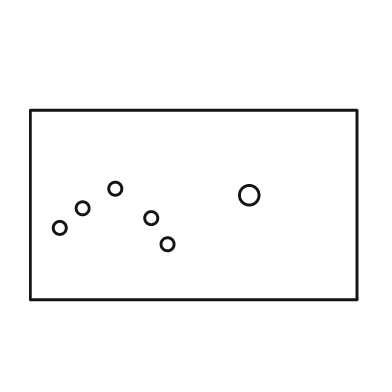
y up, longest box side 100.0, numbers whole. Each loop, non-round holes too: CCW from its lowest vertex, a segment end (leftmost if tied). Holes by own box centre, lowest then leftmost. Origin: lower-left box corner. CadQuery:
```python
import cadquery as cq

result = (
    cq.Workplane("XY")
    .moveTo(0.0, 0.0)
    .lineTo(100.0, 0.0)
    .lineTo(100.0, 58.0)
    .lineTo(0.0, 58.0)
    .close()
    .moveTo(42.0, 17.0)
    .circle(2.0)
    .moveTo(9.0, 22.0)
    .circle(2.0)
    .moveTo(37.0, 25.0)
    .circle(2.0)
    .moveTo(16.0, 28.0)
    .circle(2.0)
    .moveTo(67.0, 32.0)
    .circle(3.0)
    .moveTo(26.0, 34.0)
    .circle(2.0)
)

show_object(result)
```